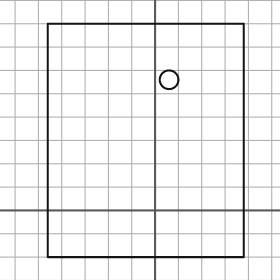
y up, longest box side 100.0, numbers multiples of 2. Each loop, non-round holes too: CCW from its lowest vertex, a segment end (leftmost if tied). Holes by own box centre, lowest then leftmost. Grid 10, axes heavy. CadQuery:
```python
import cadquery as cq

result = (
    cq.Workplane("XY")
    .moveTo(-46.0, -20.0)
    .lineTo(38.0, -20.0)
    .lineTo(38.0, 80.0)
    .lineTo(-46.0, 80.0)
    .close()
    .moveTo(6.0, 56.0)
    .circle(4.0)
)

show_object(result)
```